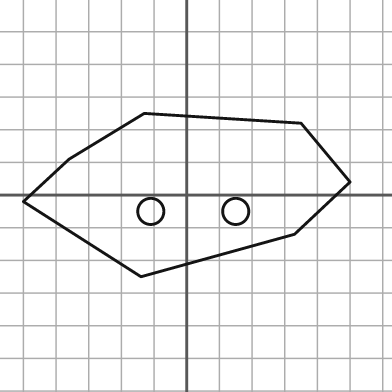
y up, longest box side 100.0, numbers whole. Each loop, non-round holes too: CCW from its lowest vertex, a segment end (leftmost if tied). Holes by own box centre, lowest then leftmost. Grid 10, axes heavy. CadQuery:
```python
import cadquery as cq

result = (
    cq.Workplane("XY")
    .moveTo(-14.0, -25.0)
    .lineTo(33.0, -12.0)
    .lineTo(50.0, 4.0)
    .lineTo(35.0, 22.0)
    .lineTo(-13.0, 25.0)
    .lineTo(-36.0, 11.0)
    .lineTo(-50.0, -2.0)
    .close()
    .moveTo(-11.0, -5.0)
    .circle(4.0)
    .moveTo(15.0, -5.0)
    .circle(4.0)
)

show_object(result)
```